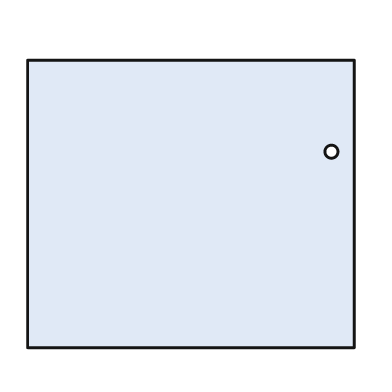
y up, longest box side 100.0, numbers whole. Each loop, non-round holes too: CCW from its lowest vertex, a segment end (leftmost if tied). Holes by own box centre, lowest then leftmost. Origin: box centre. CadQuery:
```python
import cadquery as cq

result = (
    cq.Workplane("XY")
    .moveTo(-50.0, -44.0)
    .lineTo(50.0, -44.0)
    .lineTo(50.0, 44.0)
    .lineTo(-50.0, 44.0)
    .close()
    .moveTo(43.0, 16.0)
    .circle(2.0)
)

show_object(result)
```